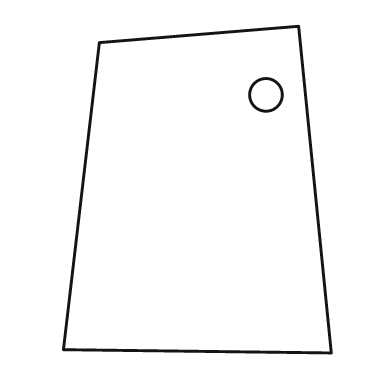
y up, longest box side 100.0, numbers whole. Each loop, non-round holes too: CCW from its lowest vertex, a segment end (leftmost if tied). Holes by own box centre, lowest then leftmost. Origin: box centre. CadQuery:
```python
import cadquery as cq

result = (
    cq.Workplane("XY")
    .moveTo(41.0, -50.0)
    .lineTo(31.0, 50.0)
    .lineTo(-30.0, 45.0)
    .lineTo(-41.0, -49.0)
    .close()
    .moveTo(21.0, 29.0)
    .circle(5.0)
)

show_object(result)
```